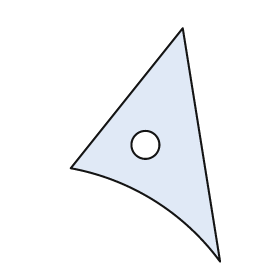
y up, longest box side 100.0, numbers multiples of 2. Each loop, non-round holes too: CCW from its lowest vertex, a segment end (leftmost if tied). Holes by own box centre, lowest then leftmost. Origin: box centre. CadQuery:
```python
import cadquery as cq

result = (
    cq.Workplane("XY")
    .moveTo(32.0, -50.0)
    .lineTo(16.0, 50.0)
    .lineTo(-32.0, -10.0)
    .threePointArc((4.0, -24.0), (32.0, -50.0))
    .close()
    .moveTo(0.0, 0.0)
    .circle(6.0)
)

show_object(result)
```